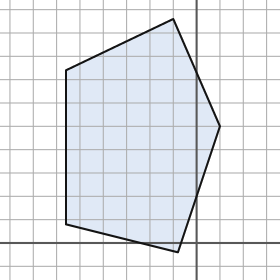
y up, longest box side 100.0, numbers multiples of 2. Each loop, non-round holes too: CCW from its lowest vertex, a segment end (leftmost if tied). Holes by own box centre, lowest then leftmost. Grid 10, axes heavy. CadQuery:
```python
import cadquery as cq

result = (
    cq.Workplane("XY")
    .moveTo(-8.0, -4.0)
    .lineTo(10.0, 50.0)
    .lineTo(-10.0, 96.0)
    .lineTo(-56.0, 74.0)
    .lineTo(-56.0, 8.0)
    .close()
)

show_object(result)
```